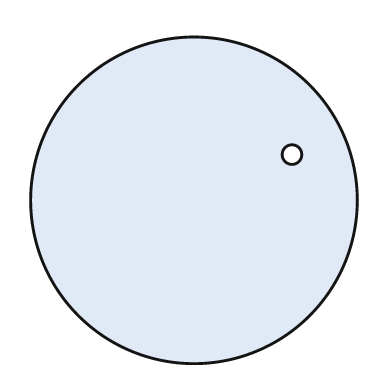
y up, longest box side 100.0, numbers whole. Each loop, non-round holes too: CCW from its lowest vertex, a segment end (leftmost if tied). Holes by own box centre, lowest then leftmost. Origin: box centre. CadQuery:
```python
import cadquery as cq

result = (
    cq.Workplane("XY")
    .moveTo(0.0, 0.0)
    .circle(50.0)
    .moveTo(30.0, 14.0)
    .circle(3.0)
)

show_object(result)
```